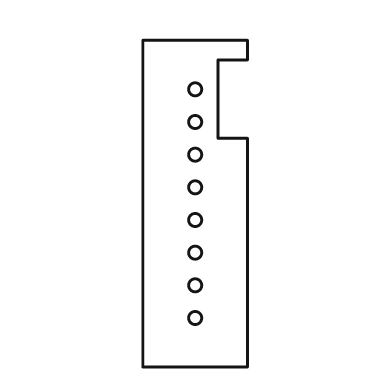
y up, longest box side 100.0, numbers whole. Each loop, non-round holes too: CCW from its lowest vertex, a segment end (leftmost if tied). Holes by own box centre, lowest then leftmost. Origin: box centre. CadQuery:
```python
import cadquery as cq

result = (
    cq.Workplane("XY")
    .moveTo(-16.0, -50.0)
    .lineTo(16.0, -50.0)
    .lineTo(16.0, 20.0)
    .lineTo(7.0, 20.0)
    .lineTo(7.0, 44.0)
    .lineTo(16.0, 44.0)
    .lineTo(16.0, 50.0)
    .lineTo(-16.0, 50.0)
    .close()
    .moveTo(0.0, -35.0)
    .circle(2.0)
    .moveTo(0.0, -25.0)
    .circle(2.0)
    .moveTo(0.0, -15.0)
    .circle(2.0)
    .moveTo(0.0, -5.0)
    .circle(2.0)
    .moveTo(0.0, 5.0)
    .circle(2.0)
    .moveTo(0.0, 15.0)
    .circle(2.0)
    .moveTo(0.0, 25.0)
    .circle(2.0)
    .moveTo(0.0, 35.0)
    .circle(2.0)
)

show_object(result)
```